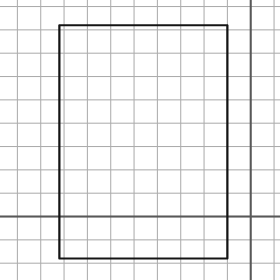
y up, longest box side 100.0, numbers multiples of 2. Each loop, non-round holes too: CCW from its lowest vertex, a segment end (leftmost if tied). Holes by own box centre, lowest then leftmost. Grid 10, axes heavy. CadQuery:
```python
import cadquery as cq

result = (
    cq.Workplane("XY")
    .moveTo(-82.0, -18.0)
    .lineTo(-10.0, -18.0)
    .lineTo(-10.0, 82.0)
    .lineTo(-82.0, 82.0)
    .close()
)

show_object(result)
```